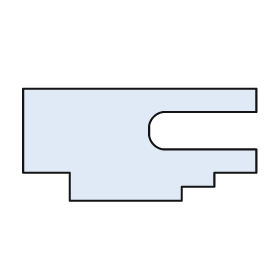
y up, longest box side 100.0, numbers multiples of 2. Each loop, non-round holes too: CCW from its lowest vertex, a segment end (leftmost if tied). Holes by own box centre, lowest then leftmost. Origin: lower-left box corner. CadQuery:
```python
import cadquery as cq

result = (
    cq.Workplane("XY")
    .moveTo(20.0, 0.0)
    .lineTo(68.0, 0.0)
    .lineTo(68.0, 6.0)
    .lineTo(82.0, 6.0)
    .lineTo(82.0, 12.0)
    .lineTo(100.0, 12.0)
    .lineTo(100.0, 22.0)
    .lineTo(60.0, 22.0)
    .threePointArc((56.0, 24.0), (54.0, 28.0))
    .lineTo(54.0, 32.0)
    .threePointArc((56.0, 36.0), (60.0, 38.0))
    .lineTo(100.0, 38.0)
    .lineTo(100.0, 48.0)
    .lineTo(0.0, 48.0)
    .lineTo(0.0, 12.0)
    .lineTo(20.0, 12.0)
    .close()
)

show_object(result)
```